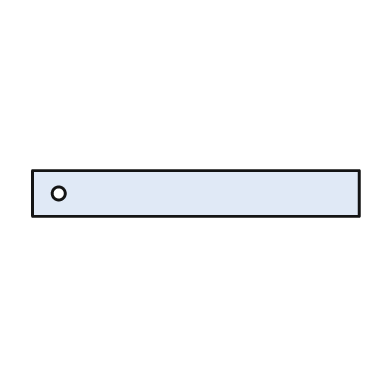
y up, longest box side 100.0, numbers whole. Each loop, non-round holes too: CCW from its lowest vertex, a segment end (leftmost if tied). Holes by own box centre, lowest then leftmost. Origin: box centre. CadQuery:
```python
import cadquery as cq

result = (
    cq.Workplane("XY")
    .moveTo(-50.0, -7.0)
    .lineTo(50.0, -7.0)
    .lineTo(50.0, 7.0)
    .lineTo(-50.0, 7.0)
    .close()
    .moveTo(-42.0, 0.0)
    .circle(2.0)
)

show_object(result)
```